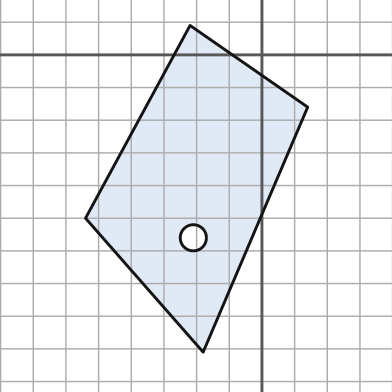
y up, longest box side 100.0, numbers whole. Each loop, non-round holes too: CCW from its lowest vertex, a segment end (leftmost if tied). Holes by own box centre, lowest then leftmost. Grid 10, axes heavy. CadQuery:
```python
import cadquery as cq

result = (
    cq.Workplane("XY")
    .moveTo(-18.0, -91.0)
    .lineTo(14.0, -16.0)
    .lineTo(-22.0, 9.0)
    .lineTo(-54.0, -50.0)
    .close()
    .moveTo(-21.0, -56.0)
    .circle(4.0)
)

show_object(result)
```